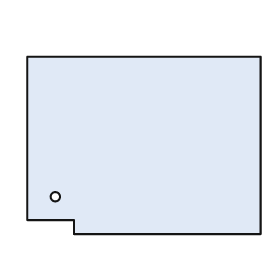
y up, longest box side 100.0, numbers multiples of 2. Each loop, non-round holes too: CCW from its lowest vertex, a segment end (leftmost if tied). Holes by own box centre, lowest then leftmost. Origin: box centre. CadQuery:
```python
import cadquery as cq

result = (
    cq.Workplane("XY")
    .moveTo(-30.0, -38.0)
    .lineTo(50.0, -38.0)
    .lineTo(50.0, 38.0)
    .lineTo(-50.0, 38.0)
    .lineTo(-50.0, -32.0)
    .lineTo(-30.0, -32.0)
    .close()
    .moveTo(-38.0, -22.0)
    .circle(2.0)
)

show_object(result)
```